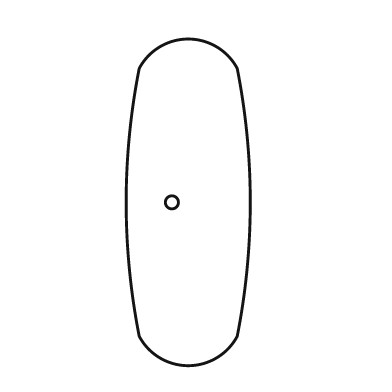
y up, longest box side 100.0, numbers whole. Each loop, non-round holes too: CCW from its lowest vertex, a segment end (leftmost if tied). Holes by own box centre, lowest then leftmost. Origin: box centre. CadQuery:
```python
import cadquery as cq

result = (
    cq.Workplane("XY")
    .moveTo(-15.0, -41.0)
    .threePointArc((0.0, -50.0), (15.0, -41.0))
    .threePointArc((19.0, 0.0), (15.0, 41.0))
    .threePointArc((0.0, 50.0), (-15.0, 41.0))
    .threePointArc((-19.0, 0.0), (-15.0, -41.0))
    .close()
    .moveTo(-5.0, 0.0)
    .circle(2.0)
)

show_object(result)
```